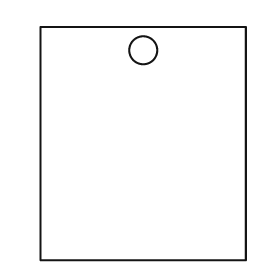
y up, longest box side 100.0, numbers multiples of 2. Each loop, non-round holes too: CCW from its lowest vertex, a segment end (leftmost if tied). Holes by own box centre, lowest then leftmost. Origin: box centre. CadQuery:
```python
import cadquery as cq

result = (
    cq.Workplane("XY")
    .moveTo(-44.0, -50.0)
    .lineTo(44.0, -50.0)
    .lineTo(44.0, 50.0)
    .lineTo(-44.0, 50.0)
    .close()
    .moveTo(0.0, 40.0)
    .circle(6.0)
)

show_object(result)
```